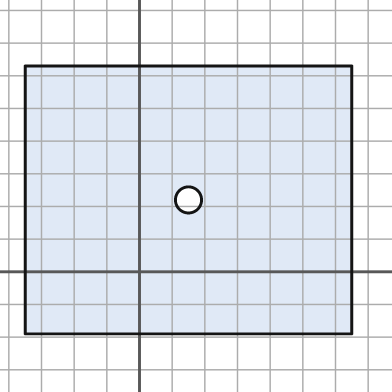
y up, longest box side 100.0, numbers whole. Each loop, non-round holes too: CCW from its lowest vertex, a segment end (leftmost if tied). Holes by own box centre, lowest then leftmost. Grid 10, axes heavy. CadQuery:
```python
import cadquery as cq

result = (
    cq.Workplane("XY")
    .moveTo(-35.0, -19.0)
    .lineTo(65.0, -19.0)
    .lineTo(65.0, 63.0)
    .lineTo(-35.0, 63.0)
    .close()
    .moveTo(15.0, 22.0)
    .circle(4.0)
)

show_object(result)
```